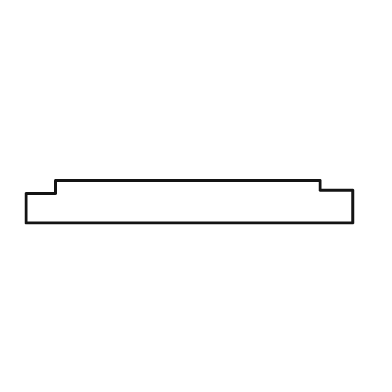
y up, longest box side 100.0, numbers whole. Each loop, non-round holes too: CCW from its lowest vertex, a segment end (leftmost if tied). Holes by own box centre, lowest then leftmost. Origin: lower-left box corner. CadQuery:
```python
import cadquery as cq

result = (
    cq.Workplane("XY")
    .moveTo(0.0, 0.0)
    .lineTo(100.0, 0.0)
    .lineTo(100.0, 10.0)
    .lineTo(90.0, 10.0)
    .lineTo(90.0, 13.0)
    .lineTo(9.0, 13.0)
    .lineTo(9.0, 9.0)
    .lineTo(0.0, 9.0)
    .close()
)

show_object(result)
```